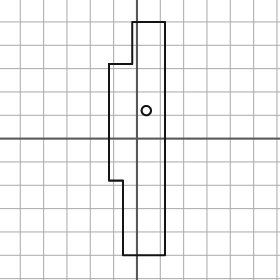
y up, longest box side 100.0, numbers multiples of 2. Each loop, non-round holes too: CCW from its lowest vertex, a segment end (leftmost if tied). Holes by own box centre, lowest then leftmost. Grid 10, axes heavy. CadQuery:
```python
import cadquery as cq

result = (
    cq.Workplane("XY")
    .moveTo(-6.0, -50.0)
    .lineTo(12.0, -50.0)
    .lineTo(12.0, 50.0)
    .lineTo(-2.0, 50.0)
    .lineTo(-2.0, 32.0)
    .lineTo(-12.0, 32.0)
    .lineTo(-12.0, -18.0)
    .lineTo(-6.0, -18.0)
    .close()
    .moveTo(4.0, 12.0)
    .circle(2.0)
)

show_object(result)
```